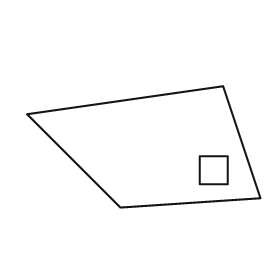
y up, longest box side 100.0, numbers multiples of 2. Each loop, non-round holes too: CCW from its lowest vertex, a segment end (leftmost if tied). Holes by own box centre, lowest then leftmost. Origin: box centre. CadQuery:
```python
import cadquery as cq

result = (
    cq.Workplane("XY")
    .moveTo(-10.0, -26.0)
    .lineTo(50.0, -22.0)
    .lineTo(34.0, 26.0)
    .lineTo(-50.0, 14.0)
    .close()
    .moveTo(24.0, -16.0)
    .lineTo(36.0, -16.0)
    .lineTo(36.0, -4.0)
    .lineTo(24.0, -4.0)
    .close()
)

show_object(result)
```